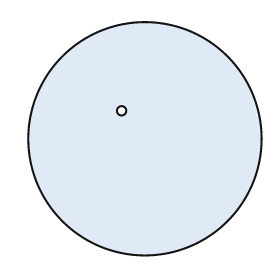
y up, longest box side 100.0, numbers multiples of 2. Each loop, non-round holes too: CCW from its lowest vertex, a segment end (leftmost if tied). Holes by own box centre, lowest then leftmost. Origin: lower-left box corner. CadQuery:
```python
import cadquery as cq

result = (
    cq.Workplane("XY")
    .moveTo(50.0, 50.0)
    .circle(50.0)
    .moveTo(40.0, 62.0)
    .circle(2.0)
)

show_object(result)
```